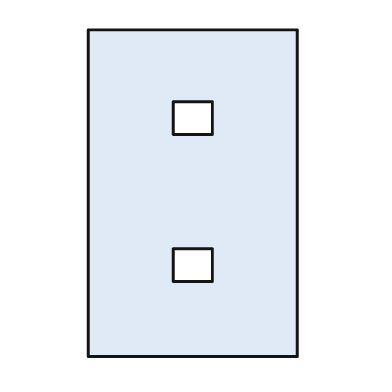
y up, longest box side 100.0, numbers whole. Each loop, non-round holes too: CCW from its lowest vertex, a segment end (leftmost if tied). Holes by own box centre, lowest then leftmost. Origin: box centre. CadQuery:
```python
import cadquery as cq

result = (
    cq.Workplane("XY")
    .moveTo(-32.0, -50.0)
    .lineTo(32.0, -50.0)
    .lineTo(32.0, 50.0)
    .lineTo(-32.0, 50.0)
    .close()
    .moveTo(-6.0, -27.0)
    .lineTo(6.0, -27.0)
    .lineTo(6.0, -17.0)
    .lineTo(-6.0, -17.0)
    .close()
    .moveTo(-6.0, 18.0)
    .lineTo(6.0, 18.0)
    .lineTo(6.0, 28.0)
    .lineTo(-6.0, 28.0)
    .close()
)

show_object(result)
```